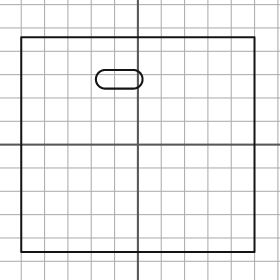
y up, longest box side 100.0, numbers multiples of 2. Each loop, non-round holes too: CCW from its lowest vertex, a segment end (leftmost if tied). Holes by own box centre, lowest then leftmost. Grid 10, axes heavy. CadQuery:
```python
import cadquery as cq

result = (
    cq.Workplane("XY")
    .moveTo(-50.0, -46.0)
    .lineTo(50.0, -46.0)
    .lineTo(50.0, 46.0)
    .lineTo(-50.0, 46.0)
    .close()
    .moveTo(-14.0, 24.0)
    .lineTo(-2.0, 24.0)
    .threePointArc((2.0, 28.0), (-2.0, 32.0))
    .lineTo(-14.0, 32.0)
    .threePointArc((-18.0, 28.0), (-14.0, 24.0))
    .close()
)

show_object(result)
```